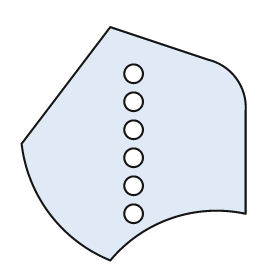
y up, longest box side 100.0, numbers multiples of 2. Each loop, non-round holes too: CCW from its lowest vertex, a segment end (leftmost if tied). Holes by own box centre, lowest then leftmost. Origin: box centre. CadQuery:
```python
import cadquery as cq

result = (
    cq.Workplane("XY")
    .moveTo(-10.0, -50.0)
    .threePointArc((16.0, -32.0), (48.0, -30.0))
    .lineTo(48.0, 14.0)
    .threePointArc((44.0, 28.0), (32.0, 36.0))
    .lineTo(-10.0, 50.0)
    .lineTo(-48.0, 0.0)
    .threePointArc((-36.0, -30.0), (-10.0, -50.0))
    .close()
    .moveTo(0.0, -30.0)
    .circle(4.0)
    .moveTo(0.0, -18.0)
    .circle(4.0)
    .moveTo(0.0, -6.0)
    .circle(4.0)
    .moveTo(0.0, 6.0)
    .circle(4.0)
    .moveTo(0.0, 18.0)
    .circle(4.0)
    .moveTo(0.0, 30.0)
    .circle(4.0)
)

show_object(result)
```